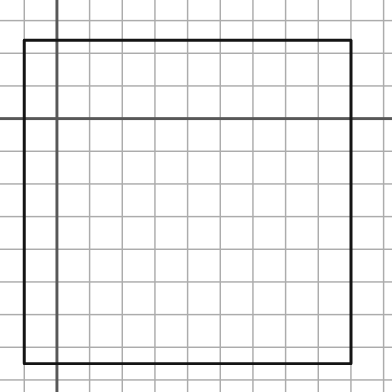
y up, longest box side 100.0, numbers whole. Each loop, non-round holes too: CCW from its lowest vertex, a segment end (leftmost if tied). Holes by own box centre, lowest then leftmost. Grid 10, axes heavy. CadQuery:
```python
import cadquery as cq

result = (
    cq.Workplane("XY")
    .moveTo(-10.0, -75.0)
    .lineTo(90.0, -75.0)
    .lineTo(90.0, 24.0)
    .lineTo(-10.0, 24.0)
    .close()
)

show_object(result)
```